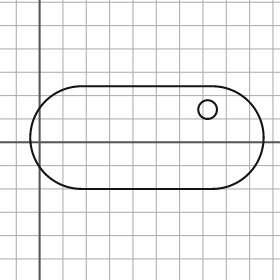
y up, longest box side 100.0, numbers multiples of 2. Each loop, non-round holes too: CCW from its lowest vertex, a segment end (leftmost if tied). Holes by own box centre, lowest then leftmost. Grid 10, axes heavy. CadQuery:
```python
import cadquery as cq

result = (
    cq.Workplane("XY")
    .moveTo(18.0, -20.0)
    .lineTo(74.0, -20.0)
    .threePointArc((96.0, 2.0), (74.0, 24.0))
    .lineTo(18.0, 24.0)
    .threePointArc((-4.0, 2.0), (18.0, -20.0))
    .close()
    .moveTo(72.0, 14.0)
    .circle(4.0)
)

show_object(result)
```